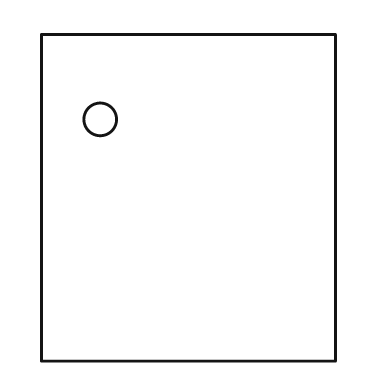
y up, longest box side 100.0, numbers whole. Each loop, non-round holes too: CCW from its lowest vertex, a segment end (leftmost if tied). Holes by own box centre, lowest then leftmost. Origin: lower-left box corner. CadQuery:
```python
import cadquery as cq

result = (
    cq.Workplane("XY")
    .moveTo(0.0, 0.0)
    .lineTo(90.0, 0.0)
    .lineTo(90.0, 100.0)
    .lineTo(0.0, 100.0)
    .close()
    .moveTo(18.0, 74.0)
    .circle(5.0)
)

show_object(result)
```